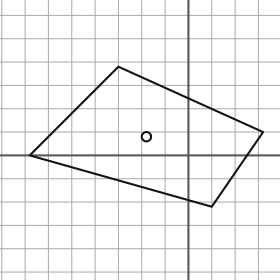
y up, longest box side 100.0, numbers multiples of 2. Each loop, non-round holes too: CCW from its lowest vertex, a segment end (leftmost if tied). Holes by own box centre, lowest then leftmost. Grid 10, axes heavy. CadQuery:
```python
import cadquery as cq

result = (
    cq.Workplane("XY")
    .moveTo(10.0, -22.0)
    .lineTo(32.0, 10.0)
    .lineTo(-30.0, 38.0)
    .lineTo(-68.0, 0.0)
    .close()
    .moveTo(-18.0, 8.0)
    .circle(2.0)
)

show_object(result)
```